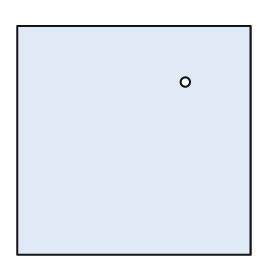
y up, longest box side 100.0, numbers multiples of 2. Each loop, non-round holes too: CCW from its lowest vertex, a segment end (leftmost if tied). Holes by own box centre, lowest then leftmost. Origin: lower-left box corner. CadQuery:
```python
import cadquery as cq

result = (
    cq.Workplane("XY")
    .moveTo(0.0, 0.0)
    .lineTo(100.0, 0.0)
    .lineTo(100.0, 98.0)
    .lineTo(0.0, 98.0)
    .close()
    .moveTo(72.0, 74.0)
    .circle(2.0)
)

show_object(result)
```